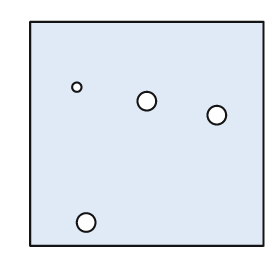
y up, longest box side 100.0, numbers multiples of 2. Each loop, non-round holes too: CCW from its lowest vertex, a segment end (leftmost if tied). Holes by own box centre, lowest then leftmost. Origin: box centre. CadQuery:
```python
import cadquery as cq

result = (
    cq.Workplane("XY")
    .moveTo(-50.0, -48.0)
    .lineTo(50.0, -48.0)
    .lineTo(50.0, 48.0)
    .lineTo(-50.0, 48.0)
    .close()
    .moveTo(-26.0, -38.0)
    .circle(4.0)
    .moveTo(30.0, 8.0)
    .circle(4.0)
    .moveTo(0.0, 14.0)
    .circle(4.0)
    .moveTo(-30.0, 20.0)
    .circle(2.0)
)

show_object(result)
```